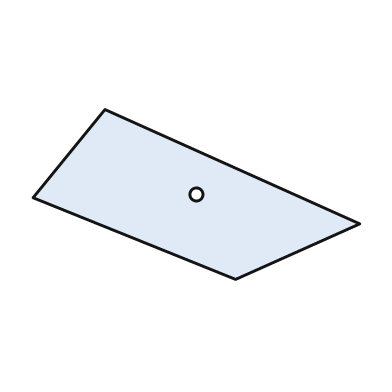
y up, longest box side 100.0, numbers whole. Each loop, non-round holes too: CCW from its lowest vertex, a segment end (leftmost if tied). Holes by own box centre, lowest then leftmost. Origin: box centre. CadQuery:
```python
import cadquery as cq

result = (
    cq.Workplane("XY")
    .moveTo(12.0, -26.0)
    .lineTo(50.0, -9.0)
    .lineTo(-28.0, 26.0)
    .lineTo(-50.0, -1.0)
    .close()
    .moveTo(0.0, 0.0)
    .circle(2.0)
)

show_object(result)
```